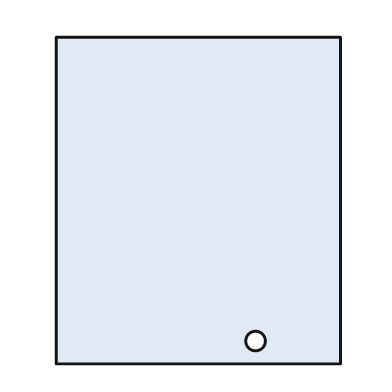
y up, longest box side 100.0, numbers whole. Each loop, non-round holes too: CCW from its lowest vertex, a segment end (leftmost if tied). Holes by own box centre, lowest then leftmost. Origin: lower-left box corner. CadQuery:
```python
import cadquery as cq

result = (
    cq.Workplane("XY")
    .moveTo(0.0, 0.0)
    .lineTo(87.0, 0.0)
    .lineTo(87.0, 100.0)
    .lineTo(0.0, 100.0)
    .close()
    .moveTo(61.0, 7.0)
    .circle(3.0)
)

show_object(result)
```